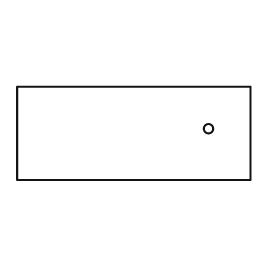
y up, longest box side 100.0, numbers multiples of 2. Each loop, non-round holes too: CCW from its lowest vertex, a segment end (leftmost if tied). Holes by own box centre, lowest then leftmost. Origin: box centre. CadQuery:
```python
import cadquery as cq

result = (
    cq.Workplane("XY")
    .moveTo(-50.0, -20.0)
    .lineTo(50.0, -20.0)
    .lineTo(50.0, 20.0)
    .lineTo(-50.0, 20.0)
    .close()
    .moveTo(32.0, 2.0)
    .circle(2.0)
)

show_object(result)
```